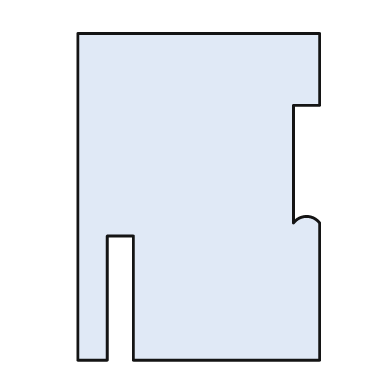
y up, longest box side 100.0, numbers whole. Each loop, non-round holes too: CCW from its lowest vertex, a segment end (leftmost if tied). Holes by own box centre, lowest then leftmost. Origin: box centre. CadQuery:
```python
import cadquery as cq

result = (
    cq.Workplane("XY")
    .moveTo(-37.0, -50.0)
    .lineTo(-28.0, -50.0)
    .lineTo(-28.0, -12.0)
    .lineTo(-20.0, -12.0)
    .lineTo(-20.0, -50.0)
    .lineTo(37.0, -50.0)
    .lineTo(37.0, -8.0)
    .threePointArc((33.0, -6.0), (29.0, -8.0))
    .lineTo(29.0, 28.0)
    .lineTo(37.0, 28.0)
    .lineTo(37.0, 50.0)
    .lineTo(-37.0, 50.0)
    .close()
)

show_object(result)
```